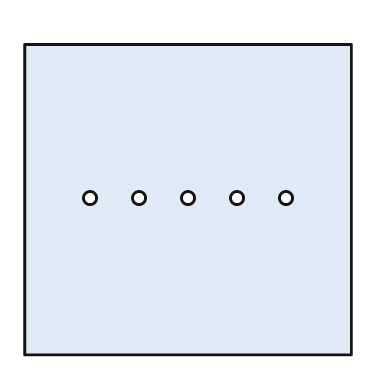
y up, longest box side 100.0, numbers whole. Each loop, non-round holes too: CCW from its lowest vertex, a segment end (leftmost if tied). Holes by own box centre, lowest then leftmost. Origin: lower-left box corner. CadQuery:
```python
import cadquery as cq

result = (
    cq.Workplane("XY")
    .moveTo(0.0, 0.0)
    .lineTo(100.0, 0.0)
    .lineTo(100.0, 95.0)
    .lineTo(0.0, 95.0)
    .close()
    .moveTo(20.0, 48.0)
    .circle(2.0)
    .moveTo(35.0, 48.0)
    .circle(2.0)
    .moveTo(50.0, 48.0)
    .circle(2.0)
    .moveTo(65.0, 48.0)
    .circle(2.0)
    .moveTo(80.0, 48.0)
    .circle(2.0)
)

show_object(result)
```